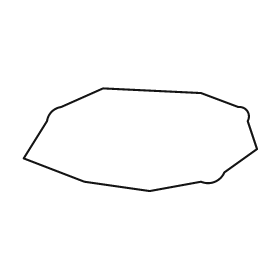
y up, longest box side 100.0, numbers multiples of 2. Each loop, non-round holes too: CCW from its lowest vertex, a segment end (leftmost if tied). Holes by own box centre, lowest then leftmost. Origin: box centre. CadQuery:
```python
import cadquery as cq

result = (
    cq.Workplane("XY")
    .moveTo(4.0, -22.0)
    .lineTo(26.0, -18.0)
    .threePointArc((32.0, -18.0), (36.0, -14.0))
    .lineTo(50.0, -4.0)
    .lineTo(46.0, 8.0)
    .threePointArc((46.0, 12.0), (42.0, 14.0))
    .lineTo(26.0, 20.0)
    .lineTo(-16.0, 22.0)
    .lineTo(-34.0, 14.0)
    .threePointArc((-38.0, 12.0), (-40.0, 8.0))
    .lineTo(-50.0, -8.0)
    .lineTo(-24.0, -18.0)
    .close()
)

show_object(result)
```